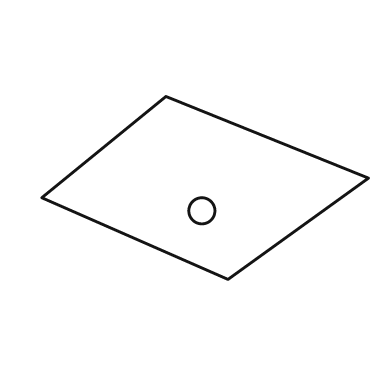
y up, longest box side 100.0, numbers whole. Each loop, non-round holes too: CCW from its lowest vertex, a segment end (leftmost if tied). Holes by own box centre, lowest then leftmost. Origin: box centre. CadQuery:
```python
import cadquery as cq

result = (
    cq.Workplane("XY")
    .moveTo(7.0, -28.0)
    .lineTo(50.0, 3.0)
    .lineTo(-12.0, 28.0)
    .lineTo(-50.0, -3.0)
    .close()
    .moveTo(-1.0, -7.0)
    .circle(4.0)
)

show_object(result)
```